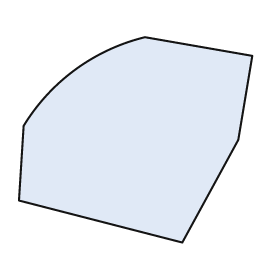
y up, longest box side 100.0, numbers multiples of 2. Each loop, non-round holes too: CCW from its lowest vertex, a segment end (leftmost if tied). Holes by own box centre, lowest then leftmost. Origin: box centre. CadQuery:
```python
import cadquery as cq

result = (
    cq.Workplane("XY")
    .moveTo(20.0, -44.0)
    .lineTo(44.0, 0.0)
    .lineTo(50.0, 36.0)
    .lineTo(4.0, 44.0)
    .threePointArc((-26.0, 30.0), (-48.0, 6.0))
    .lineTo(-50.0, -26.0)
    .close()
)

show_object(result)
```